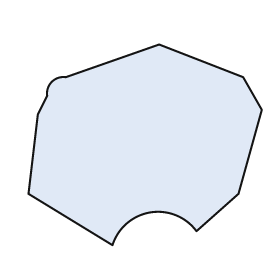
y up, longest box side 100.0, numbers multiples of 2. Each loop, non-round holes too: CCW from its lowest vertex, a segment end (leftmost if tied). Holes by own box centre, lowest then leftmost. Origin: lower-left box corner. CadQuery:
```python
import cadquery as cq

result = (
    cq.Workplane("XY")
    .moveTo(36.0, 0.0)
    .threePointArc((52.0, 14.0), (72.0, 6.0))
    .lineTo(90.0, 22.0)
    .lineTo(100.0, 58.0)
    .lineTo(92.0, 72.0)
    .lineTo(56.0, 86.0)
    .lineTo(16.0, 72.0)
    .threePointArc((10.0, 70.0), (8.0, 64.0))
    .lineTo(4.0, 56.0)
    .lineTo(0.0, 22.0)
    .close()
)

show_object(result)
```